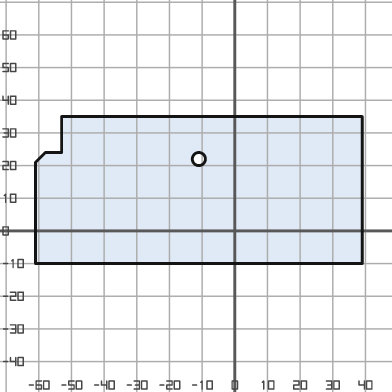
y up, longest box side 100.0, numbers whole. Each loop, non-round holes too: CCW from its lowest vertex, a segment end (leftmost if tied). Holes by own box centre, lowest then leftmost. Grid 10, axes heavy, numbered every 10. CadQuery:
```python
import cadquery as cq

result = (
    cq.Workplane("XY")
    .moveTo(-61.0, -10.0)
    .lineTo(39.0, -10.0)
    .lineTo(39.0, 35.0)
    .lineTo(-53.0, 35.0)
    .lineTo(-53.0, 24.0)
    .lineTo(-58.0, 24.0)
    .lineTo(-61.0, 21.0)
    .close()
    .moveTo(-11.0, 22.0)
    .circle(2.0)
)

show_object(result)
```